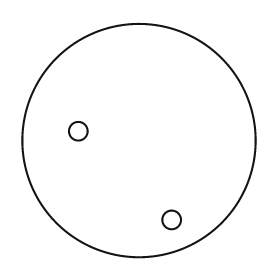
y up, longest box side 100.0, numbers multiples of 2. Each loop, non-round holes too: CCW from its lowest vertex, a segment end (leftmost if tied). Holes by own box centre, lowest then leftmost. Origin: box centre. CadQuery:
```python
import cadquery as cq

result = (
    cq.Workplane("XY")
    .moveTo(0.0, 0.0)
    .circle(50.0)
    .moveTo(14.0, -34.0)
    .circle(4.0)
    .moveTo(-26.0, 4.0)
    .circle(4.0)
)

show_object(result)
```